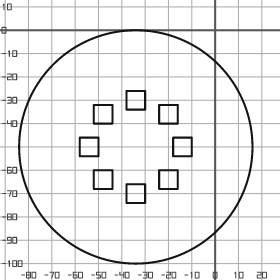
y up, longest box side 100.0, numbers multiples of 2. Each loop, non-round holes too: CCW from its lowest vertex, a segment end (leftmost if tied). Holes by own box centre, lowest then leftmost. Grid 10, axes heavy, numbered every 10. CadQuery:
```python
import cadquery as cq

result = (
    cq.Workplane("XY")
    .moveTo(-34.0, -50.0)
    .circle(50.0)
    .moveTo(-38.0, -74.0)
    .lineTo(-30.0, -74.0)
    .lineTo(-30.0, -66.0)
    .lineTo(-38.0, -66.0)
    .close()
    .moveTo(-52.0, -68.0)
    .lineTo(-44.0, -68.0)
    .lineTo(-44.0, -60.0)
    .lineTo(-52.0, -60.0)
    .close()
    .moveTo(-24.0, -68.0)
    .lineTo(-16.0, -68.0)
    .lineTo(-16.0, -60.0)
    .lineTo(-24.0, -60.0)
    .close()
    .moveTo(-58.0, -54.0)
    .lineTo(-50.0, -54.0)
    .lineTo(-50.0, -46.0)
    .lineTo(-58.0, -46.0)
    .close()
    .moveTo(-18.0, -54.0)
    .lineTo(-10.0, -54.0)
    .lineTo(-10.0, -46.0)
    .lineTo(-18.0, -46.0)
    .close()
    .moveTo(-52.0, -40.0)
    .lineTo(-44.0, -40.0)
    .lineTo(-44.0, -32.0)
    .lineTo(-52.0, -32.0)
    .close()
    .moveTo(-24.0, -40.0)
    .lineTo(-16.0, -40.0)
    .lineTo(-16.0, -32.0)
    .lineTo(-24.0, -32.0)
    .close()
    .moveTo(-38.0, -34.0)
    .lineTo(-30.0, -34.0)
    .lineTo(-30.0, -26.0)
    .lineTo(-38.0, -26.0)
    .close()
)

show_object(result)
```